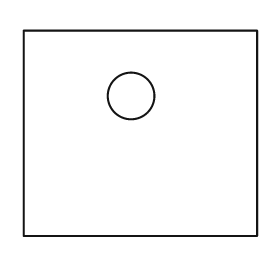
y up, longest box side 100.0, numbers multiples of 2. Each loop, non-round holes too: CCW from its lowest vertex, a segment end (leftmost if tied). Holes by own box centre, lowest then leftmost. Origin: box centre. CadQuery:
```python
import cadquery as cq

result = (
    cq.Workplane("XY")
    .moveTo(-50.0, -44.0)
    .lineTo(50.0, -44.0)
    .lineTo(50.0, 44.0)
    .lineTo(-50.0, 44.0)
    .close()
    .moveTo(-4.0, 16.0)
    .circle(10.0)
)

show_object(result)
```